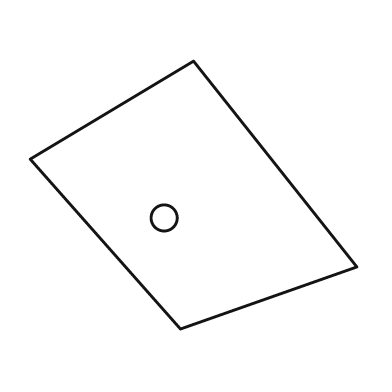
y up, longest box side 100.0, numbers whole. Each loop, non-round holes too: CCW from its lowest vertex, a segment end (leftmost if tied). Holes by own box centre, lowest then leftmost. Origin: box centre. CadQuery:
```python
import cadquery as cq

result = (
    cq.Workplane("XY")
    .moveTo(-4.0, -41.0)
    .lineTo(50.0, -22.0)
    .lineTo(0.0, 41.0)
    .lineTo(-50.0, 11.0)
    .close()
    .moveTo(-9.0, -7.0)
    .circle(4.0)
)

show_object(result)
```